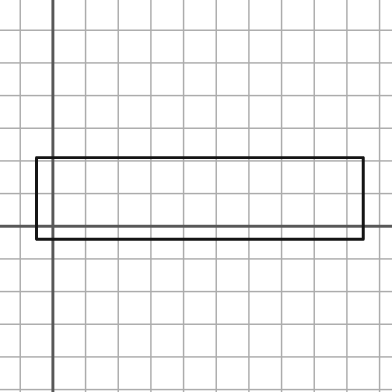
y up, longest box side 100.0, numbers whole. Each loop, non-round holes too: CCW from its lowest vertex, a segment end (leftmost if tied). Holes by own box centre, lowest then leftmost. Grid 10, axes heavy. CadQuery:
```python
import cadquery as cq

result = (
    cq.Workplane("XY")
    .moveTo(-5.0, -4.0)
    .lineTo(95.0, -4.0)
    .lineTo(95.0, 21.0)
    .lineTo(-5.0, 21.0)
    .close()
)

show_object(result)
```